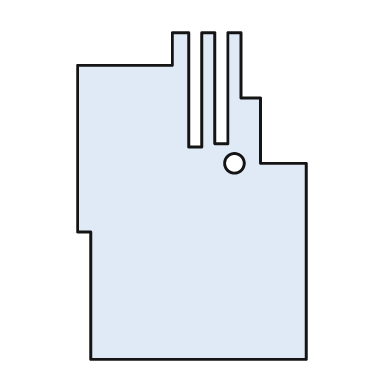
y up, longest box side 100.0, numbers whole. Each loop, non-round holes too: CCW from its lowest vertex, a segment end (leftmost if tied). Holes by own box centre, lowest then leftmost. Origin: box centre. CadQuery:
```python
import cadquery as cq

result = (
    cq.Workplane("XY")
    .moveTo(-31.0, -50.0)
    .lineTo(35.0, -50.0)
    .lineTo(35.0, 10.0)
    .lineTo(21.0, 10.0)
    .lineTo(21.0, 30.0)
    .lineTo(15.0, 30.0)
    .lineTo(15.0, 50.0)
    .lineTo(11.0, 50.0)
    .lineTo(11.0, 16.0)
    .lineTo(7.0, 16.0)
    .lineTo(7.0, 50.0)
    .lineTo(3.0, 50.0)
    .lineTo(3.0, 15.0)
    .lineTo(-1.0, 15.0)
    .lineTo(-1.0, 50.0)
    .lineTo(-6.0, 50.0)
    .lineTo(-6.0, 40.0)
    .lineTo(-35.0, 40.0)
    .lineTo(-35.0, -11.0)
    .lineTo(-31.0, -11.0)
    .close()
    .moveTo(13.0, 10.0)
    .circle(3.0)
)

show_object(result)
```